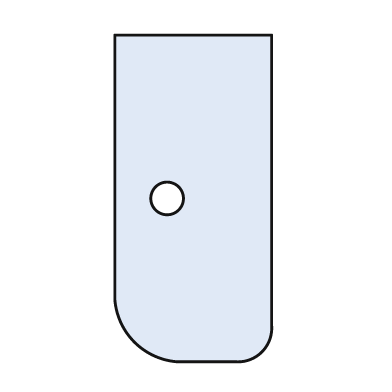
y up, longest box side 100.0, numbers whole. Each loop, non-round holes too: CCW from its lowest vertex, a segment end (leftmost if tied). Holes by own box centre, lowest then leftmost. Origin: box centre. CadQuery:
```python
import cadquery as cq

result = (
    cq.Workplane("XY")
    .moveTo(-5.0, -50.0)
    .lineTo(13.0, -50.0)
    .threePointArc((21.0, -47.0), (24.0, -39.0))
    .lineTo(24.0, 50.0)
    .lineTo(-24.0, 50.0)
    .lineTo(-24.0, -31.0)
    .threePointArc((-18.0, -44.0), (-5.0, -50.0))
    .close()
    .moveTo(-8.0, 0.0)
    .circle(5.0)
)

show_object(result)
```